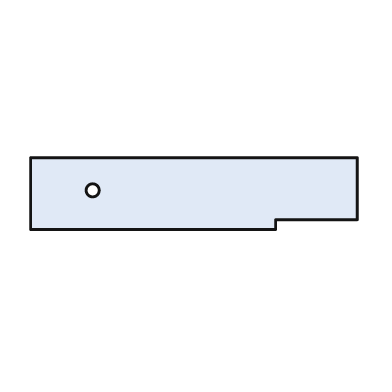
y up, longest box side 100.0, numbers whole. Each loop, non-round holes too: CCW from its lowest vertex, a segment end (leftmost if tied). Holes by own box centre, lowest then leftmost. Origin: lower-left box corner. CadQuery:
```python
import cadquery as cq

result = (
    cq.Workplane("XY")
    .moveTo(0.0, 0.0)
    .lineTo(75.0, 0.0)
    .lineTo(75.0, 3.0)
    .lineTo(100.0, 3.0)
    .lineTo(100.0, 22.0)
    .lineTo(0.0, 22.0)
    .close()
    .moveTo(19.0, 12.0)
    .circle(2.0)
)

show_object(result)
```